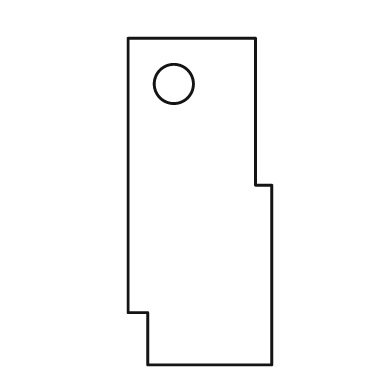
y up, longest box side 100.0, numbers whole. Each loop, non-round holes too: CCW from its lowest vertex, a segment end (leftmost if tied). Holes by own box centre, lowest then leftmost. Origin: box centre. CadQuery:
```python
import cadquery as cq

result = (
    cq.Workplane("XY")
    .moveTo(-16.0, -50.0)
    .lineTo(22.0, -50.0)
    .lineTo(22.0, 5.0)
    .lineTo(17.0, 5.0)
    .lineTo(17.0, 50.0)
    .lineTo(-22.0, 50.0)
    .lineTo(-22.0, -34.0)
    .lineTo(-16.0, -34.0)
    .close()
    .moveTo(-8.0, 36.0)
    .circle(6.0)
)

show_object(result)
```